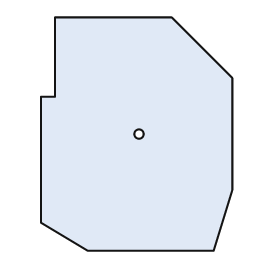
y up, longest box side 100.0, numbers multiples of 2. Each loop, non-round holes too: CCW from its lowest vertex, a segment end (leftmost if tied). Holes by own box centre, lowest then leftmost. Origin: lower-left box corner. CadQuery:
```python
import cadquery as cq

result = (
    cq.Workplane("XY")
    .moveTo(20.0, 0.0)
    .lineTo(74.0, 0.0)
    .lineTo(82.0, 26.0)
    .lineTo(82.0, 74.0)
    .lineTo(56.0, 100.0)
    .lineTo(6.0, 100.0)
    .lineTo(6.0, 66.0)
    .lineTo(0.0, 66.0)
    .lineTo(0.0, 12.0)
    .close()
    .moveTo(42.0, 50.0)
    .circle(2.0)
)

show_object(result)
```